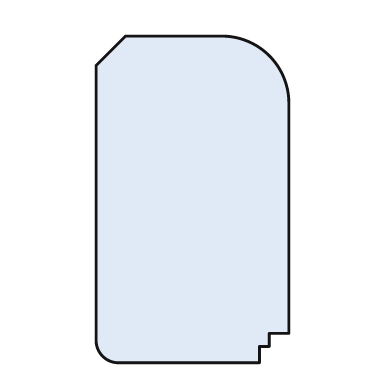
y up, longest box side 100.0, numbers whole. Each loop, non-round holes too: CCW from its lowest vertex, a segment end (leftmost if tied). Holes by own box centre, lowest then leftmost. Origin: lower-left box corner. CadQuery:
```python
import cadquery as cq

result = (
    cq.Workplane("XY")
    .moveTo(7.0, 0.0)
    .lineTo(50.0, 0.0)
    .lineTo(50.0, 5.0)
    .lineTo(53.0, 5.0)
    .lineTo(53.0, 9.0)
    .lineTo(59.0, 9.0)
    .lineTo(59.0, 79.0)
    .threePointArc((53.0, 94.0), (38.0, 100.0))
    .lineTo(9.0, 100.0)
    .lineTo(0.0, 91.0)
    .lineTo(0.0, 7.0)
    .threePointArc((2.0, 2.0), (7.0, 0.0))
    .close()
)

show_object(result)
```